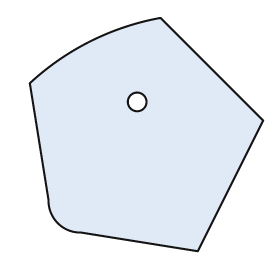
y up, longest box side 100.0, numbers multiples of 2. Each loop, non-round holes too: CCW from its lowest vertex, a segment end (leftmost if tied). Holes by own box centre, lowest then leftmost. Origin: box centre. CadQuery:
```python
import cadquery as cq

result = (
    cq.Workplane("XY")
    .moveTo(22.0, -50.0)
    .lineTo(50.0, 6.0)
    .lineTo(6.0, 50.0)
    .threePointArc((-24.0, 40.0), (-50.0, 22.0))
    .lineTo(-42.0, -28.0)
    .threePointArc((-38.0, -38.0), (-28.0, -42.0))
    .close()
    .moveTo(-4.0, 14.0)
    .circle(4.0)
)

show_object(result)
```